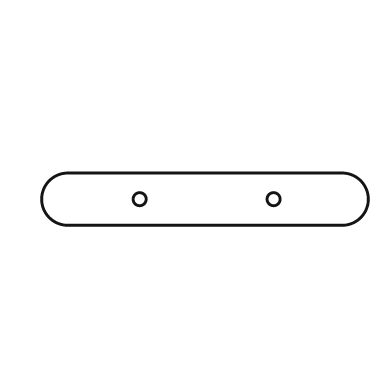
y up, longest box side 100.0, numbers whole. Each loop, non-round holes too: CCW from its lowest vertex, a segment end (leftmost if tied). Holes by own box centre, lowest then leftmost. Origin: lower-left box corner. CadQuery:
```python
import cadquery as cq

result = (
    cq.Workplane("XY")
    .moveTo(8.0, 0.0)
    .lineTo(92.0, 0.0)
    .threePointArc((100.0, 8.0), (92.0, 16.0))
    .lineTo(8.0, 16.0)
    .threePointArc((0.0, 8.0), (8.0, 0.0))
    .close()
    .moveTo(30.0, 8.0)
    .circle(2.0)
    .moveTo(71.0, 8.0)
    .circle(2.0)
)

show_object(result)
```